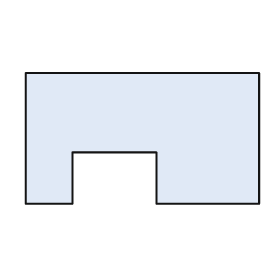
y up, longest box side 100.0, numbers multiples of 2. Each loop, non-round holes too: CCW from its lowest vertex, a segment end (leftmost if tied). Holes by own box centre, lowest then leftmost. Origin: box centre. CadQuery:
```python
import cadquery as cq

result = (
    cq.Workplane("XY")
    .moveTo(-50.0, -28.0)
    .lineTo(-30.0, -28.0)
    .lineTo(-30.0, -6.0)
    .lineTo(6.0, -6.0)
    .lineTo(6.0, -28.0)
    .lineTo(50.0, -28.0)
    .lineTo(50.0, 28.0)
    .lineTo(-50.0, 28.0)
    .close()
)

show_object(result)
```